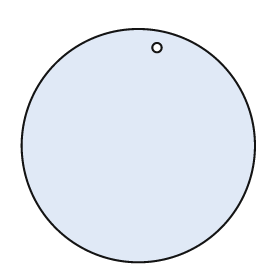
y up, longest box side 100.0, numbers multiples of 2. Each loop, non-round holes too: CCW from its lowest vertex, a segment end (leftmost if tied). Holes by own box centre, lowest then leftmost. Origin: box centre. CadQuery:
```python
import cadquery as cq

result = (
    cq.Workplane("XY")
    .moveTo(0.0, 0.0)
    .circle(50.0)
    .moveTo(8.0, 42.0)
    .circle(2.0)
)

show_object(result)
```